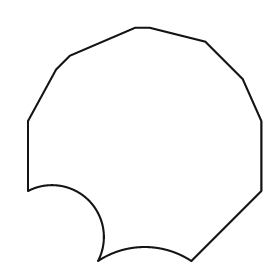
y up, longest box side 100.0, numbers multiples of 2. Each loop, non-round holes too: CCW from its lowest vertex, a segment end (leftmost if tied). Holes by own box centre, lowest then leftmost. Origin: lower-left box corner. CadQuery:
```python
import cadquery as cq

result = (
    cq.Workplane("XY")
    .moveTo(30.0, 0.0)
    .threePointArc((50.0, 6.0), (70.0, 0.0))
    .lineTo(100.0, 30.0)
    .lineTo(100.0, 60.0)
    .lineTo(92.0, 78.0)
    .lineTo(76.0, 94.0)
    .lineTo(52.0, 100.0)
    .lineTo(46.0, 100.0)
    .lineTo(18.0, 88.0)
    .lineTo(12.0, 82.0)
    .lineTo(0.0, 60.0)
    .lineTo(0.0, 30.0)
    .threePointArc((26.0, 26.0), (30.0, 0.0))
    .close()
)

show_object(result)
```